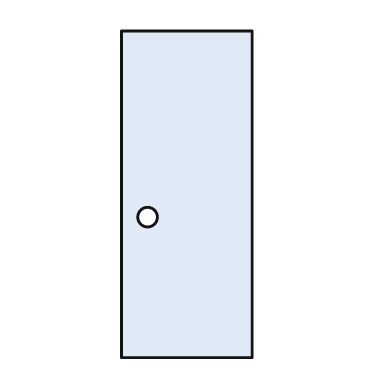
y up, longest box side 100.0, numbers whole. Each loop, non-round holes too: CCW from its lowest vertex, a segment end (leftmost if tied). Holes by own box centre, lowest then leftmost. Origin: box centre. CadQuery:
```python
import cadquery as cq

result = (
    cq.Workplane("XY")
    .moveTo(-20.0, -50.0)
    .lineTo(20.0, -50.0)
    .lineTo(20.0, 50.0)
    .lineTo(-20.0, 50.0)
    .close()
    .moveTo(-12.0, -7.0)
    .circle(3.0)
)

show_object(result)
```